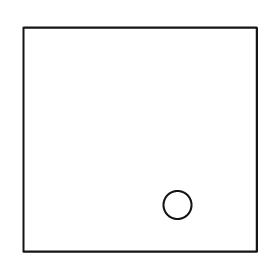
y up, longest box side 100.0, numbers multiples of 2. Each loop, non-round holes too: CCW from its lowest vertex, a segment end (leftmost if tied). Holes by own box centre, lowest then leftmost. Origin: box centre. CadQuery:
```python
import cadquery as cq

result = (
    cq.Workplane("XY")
    .moveTo(-50.0, -48.0)
    .lineTo(50.0, -48.0)
    .lineTo(50.0, 48.0)
    .lineTo(-50.0, 48.0)
    .close()
    .moveTo(16.0, -28.0)
    .circle(6.0)
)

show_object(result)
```